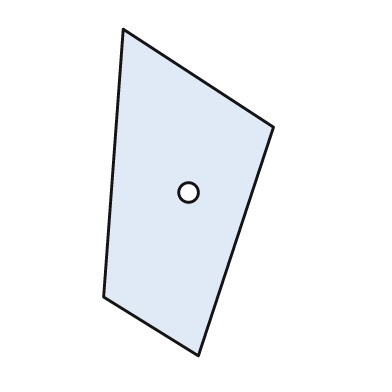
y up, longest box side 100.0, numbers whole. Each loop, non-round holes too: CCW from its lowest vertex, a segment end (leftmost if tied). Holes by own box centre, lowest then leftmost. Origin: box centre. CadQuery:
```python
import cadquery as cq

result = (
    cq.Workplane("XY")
    .moveTo(3.0, -50.0)
    .lineTo(26.0, 20.0)
    .lineTo(-20.0, 50.0)
    .lineTo(-26.0, -32.0)
    .close()
    .moveTo(0.0, 0.0)
    .circle(3.0)
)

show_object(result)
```